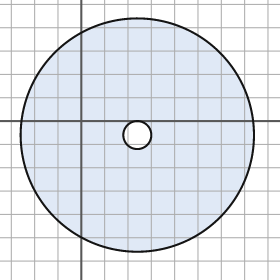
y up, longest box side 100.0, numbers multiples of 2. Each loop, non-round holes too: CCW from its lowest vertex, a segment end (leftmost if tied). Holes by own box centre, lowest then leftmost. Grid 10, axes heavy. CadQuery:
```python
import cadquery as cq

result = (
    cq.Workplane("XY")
    .moveTo(24.0, -6.0)
    .circle(50.0)
    .moveTo(24.0, -6.0)
    .circle(6.0)
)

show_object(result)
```